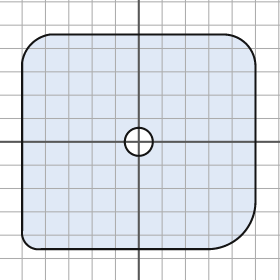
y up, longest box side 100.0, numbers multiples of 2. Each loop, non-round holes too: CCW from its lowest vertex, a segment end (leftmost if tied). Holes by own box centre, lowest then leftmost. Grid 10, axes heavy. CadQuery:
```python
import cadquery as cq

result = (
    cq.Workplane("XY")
    .moveTo(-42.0, -46.0)
    .lineTo(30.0, -46.0)
    .threePointArc((44.0, -40.0), (50.0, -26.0))
    .lineTo(50.0, 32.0)
    .threePointArc((46.0, 42.0), (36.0, 46.0))
    .lineTo(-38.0, 46.0)
    .threePointArc((-46.0, 42.0), (-50.0, 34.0))
    .lineTo(-50.0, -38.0)
    .threePointArc((-48.0, -44.0), (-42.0, -46.0))
    .close()
    .moveTo(0.0, 0.0)
    .circle(6.0)
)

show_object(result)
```